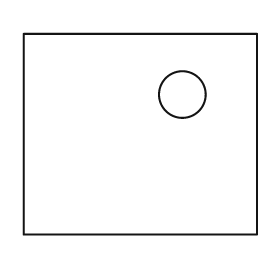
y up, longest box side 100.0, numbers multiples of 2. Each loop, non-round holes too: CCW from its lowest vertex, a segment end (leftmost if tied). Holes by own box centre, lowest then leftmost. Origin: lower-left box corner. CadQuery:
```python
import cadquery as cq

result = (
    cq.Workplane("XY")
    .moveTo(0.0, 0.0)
    .lineTo(100.0, 0.0)
    .lineTo(100.0, 86.0)
    .lineTo(0.0, 86.0)
    .close()
    .moveTo(68.0, 60.0)
    .circle(10.0)
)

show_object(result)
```